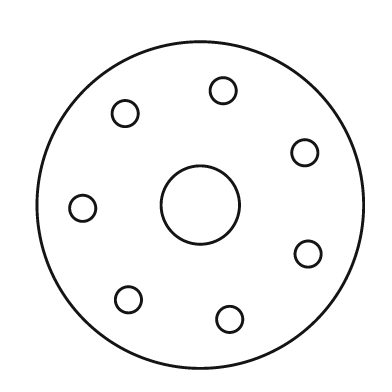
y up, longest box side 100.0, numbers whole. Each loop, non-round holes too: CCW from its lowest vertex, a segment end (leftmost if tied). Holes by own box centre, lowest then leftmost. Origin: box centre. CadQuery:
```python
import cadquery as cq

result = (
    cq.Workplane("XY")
    .moveTo(0.0, 0.0)
    .circle(50.0)
    .moveTo(9.0, -35.0)
    .circle(4.0)
    .moveTo(-22.0, -29.0)
    .circle(4.0)
    .moveTo(33.0, -15.0)
    .circle(4.0)
    .moveTo(-36.0, -1.0)
    .circle(4.0)
    .moveTo(0.0, 0.0)
    .circle(12.0)
    .moveTo(32.0, 16.0)
    .circle(4.0)
    .moveTo(-23.0, 28.0)
    .circle(4.0)
    .moveTo(7.0, 35.0)
    .circle(4.0)
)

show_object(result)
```